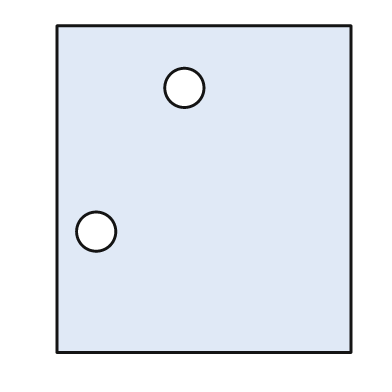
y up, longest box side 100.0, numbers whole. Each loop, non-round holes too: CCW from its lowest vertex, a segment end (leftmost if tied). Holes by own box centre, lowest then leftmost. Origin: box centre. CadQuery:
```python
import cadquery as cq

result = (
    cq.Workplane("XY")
    .moveTo(-45.0, -50.0)
    .lineTo(45.0, -50.0)
    .lineTo(45.0, 50.0)
    .lineTo(-45.0, 50.0)
    .close()
    .moveTo(-33.0, -13.0)
    .circle(6.0)
    .moveTo(-6.0, 31.0)
    .circle(6.0)
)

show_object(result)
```